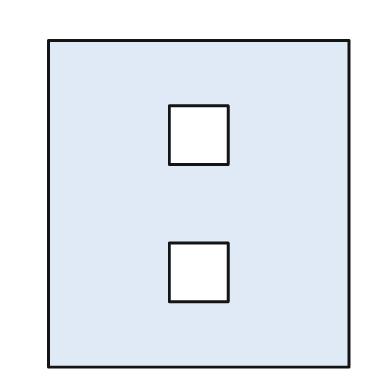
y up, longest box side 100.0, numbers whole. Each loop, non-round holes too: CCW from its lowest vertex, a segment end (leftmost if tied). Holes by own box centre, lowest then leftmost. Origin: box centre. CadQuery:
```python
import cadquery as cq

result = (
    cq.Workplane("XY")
    .moveTo(-46.0, -50.0)
    .lineTo(46.0, -50.0)
    .lineTo(46.0, 50.0)
    .lineTo(-46.0, 50.0)
    .close()
    .moveTo(-9.0, -30.0)
    .lineTo(9.0, -30.0)
    .lineTo(9.0, -12.0)
    .lineTo(-9.0, -12.0)
    .close()
    .moveTo(-9.0, 12.0)
    .lineTo(9.0, 12.0)
    .lineTo(9.0, 30.0)
    .lineTo(-9.0, 30.0)
    .close()
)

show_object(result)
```